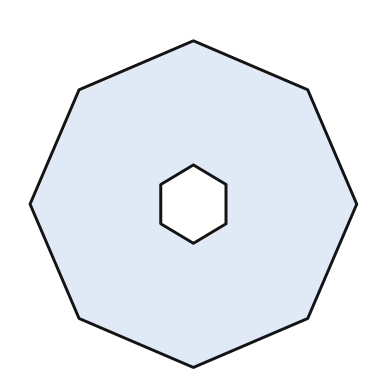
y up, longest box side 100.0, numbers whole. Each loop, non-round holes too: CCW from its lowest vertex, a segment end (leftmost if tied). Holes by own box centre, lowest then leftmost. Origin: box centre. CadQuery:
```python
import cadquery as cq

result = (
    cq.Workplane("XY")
    .moveTo(0.0, -50.0)
    .lineTo(35.0, -35.0)
    .lineTo(50.0, 0.0)
    .lineTo(35.0, 35.0)
    .lineTo(0.0, 50.0)
    .lineTo(-35.0, 35.0)
    .lineTo(-50.0, 0.0)
    .lineTo(-35.0, -35.0)
    .close()
    .moveTo(0.0, -12.0)
    .lineTo(10.0, -6.0)
    .lineTo(10.0, 6.0)
    .lineTo(0.0, 12.0)
    .lineTo(-10.0, 6.0)
    .lineTo(-10.0, -6.0)
    .close()
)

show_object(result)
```